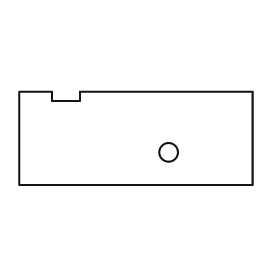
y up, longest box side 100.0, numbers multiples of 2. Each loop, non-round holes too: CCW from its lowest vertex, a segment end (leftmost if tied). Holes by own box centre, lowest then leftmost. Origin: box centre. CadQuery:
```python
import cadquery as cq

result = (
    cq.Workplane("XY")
    .moveTo(-50.0, -20.0)
    .lineTo(50.0, -20.0)
    .lineTo(50.0, 20.0)
    .lineTo(-24.0, 20.0)
    .lineTo(-24.0, 16.0)
    .lineTo(-36.0, 16.0)
    .lineTo(-36.0, 20.0)
    .lineTo(-50.0, 20.0)
    .close()
    .moveTo(14.0, -6.0)
    .circle(4.0)
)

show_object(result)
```